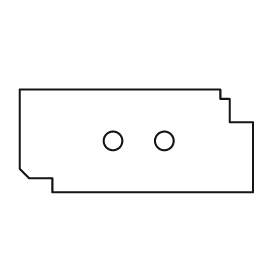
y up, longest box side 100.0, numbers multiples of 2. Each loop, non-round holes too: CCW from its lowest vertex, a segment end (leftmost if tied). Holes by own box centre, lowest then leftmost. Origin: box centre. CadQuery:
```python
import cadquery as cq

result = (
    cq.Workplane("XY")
    .moveTo(-36.0, -22.0)
    .lineTo(50.0, -22.0)
    .lineTo(50.0, 8.0)
    .lineTo(40.0, 8.0)
    .lineTo(40.0, 18.0)
    .lineTo(36.0, 18.0)
    .lineTo(36.0, 22.0)
    .lineTo(-50.0, 22.0)
    .lineTo(-50.0, -12.0)
    .lineTo(-46.0, -16.0)
    .lineTo(-36.0, -16.0)
    .close()
    .moveTo(-10.0, 0.0)
    .circle(4.0)
    .moveTo(12.0, 0.0)
    .circle(4.0)
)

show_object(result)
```